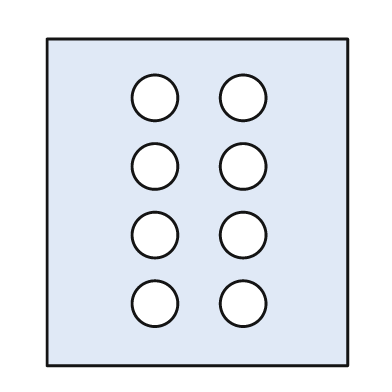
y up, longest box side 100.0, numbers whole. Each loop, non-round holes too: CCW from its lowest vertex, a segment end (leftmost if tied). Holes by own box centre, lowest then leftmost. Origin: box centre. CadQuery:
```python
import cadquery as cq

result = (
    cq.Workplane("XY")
    .moveTo(-46.0, -50.0)
    .lineTo(46.0, -50.0)
    .lineTo(46.0, 50.0)
    .lineTo(-46.0, 50.0)
    .close()
    .moveTo(-13.0, -31.0)
    .circle(7.0)
    .moveTo(14.0, -31.0)
    .circle(7.0)
    .moveTo(-13.0, -10.0)
    .circle(7.0)
    .moveTo(14.0, -10.0)
    .circle(7.0)
    .moveTo(-13.0, 11.0)
    .circle(7.0)
    .moveTo(14.0, 11.0)
    .circle(7.0)
    .moveTo(-13.0, 32.0)
    .circle(7.0)
    .moveTo(14.0, 32.0)
    .circle(7.0)
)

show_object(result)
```